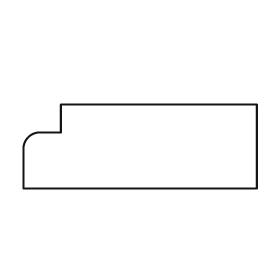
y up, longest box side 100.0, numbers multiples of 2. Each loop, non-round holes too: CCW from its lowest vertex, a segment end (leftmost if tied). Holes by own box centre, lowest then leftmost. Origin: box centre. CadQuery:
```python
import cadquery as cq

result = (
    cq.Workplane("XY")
    .moveTo(-50.0, -18.0)
    .lineTo(50.0, -18.0)
    .lineTo(50.0, 18.0)
    .lineTo(-34.0, 18.0)
    .lineTo(-34.0, 6.0)
    .lineTo(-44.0, 6.0)
    .threePointArc((-48.0, 4.0), (-50.0, 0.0))
    .close()
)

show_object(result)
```